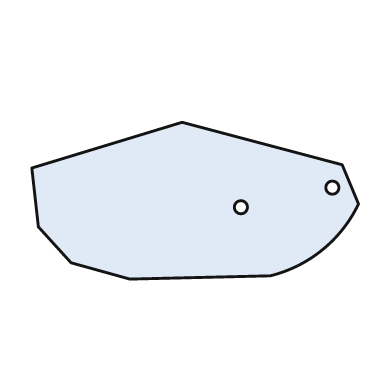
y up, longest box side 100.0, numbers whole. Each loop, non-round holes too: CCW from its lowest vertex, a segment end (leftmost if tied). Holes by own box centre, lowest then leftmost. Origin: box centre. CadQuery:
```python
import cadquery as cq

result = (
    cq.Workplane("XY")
    .moveTo(-20.0, -24.0)
    .lineTo(23.0, -23.0)
    .threePointArc((39.0, -15.0), (50.0, -1.0))
    .lineTo(45.0, 11.0)
    .lineTo(-4.0, 24.0)
    .lineTo(-50.0, 10.0)
    .lineTo(-48.0, -8.0)
    .lineTo(-38.0, -19.0)
    .close()
    .moveTo(14.0, -2.0)
    .circle(2.0)
    .moveTo(42.0, 4.0)
    .circle(2.0)
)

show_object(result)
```